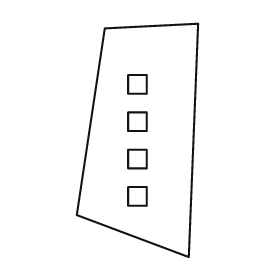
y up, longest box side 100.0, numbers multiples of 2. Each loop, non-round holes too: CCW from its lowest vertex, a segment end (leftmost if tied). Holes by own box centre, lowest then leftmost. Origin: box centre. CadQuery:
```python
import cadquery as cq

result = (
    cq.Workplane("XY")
    .moveTo(22.0, -50.0)
    .lineTo(26.0, 50.0)
    .lineTo(-14.0, 48.0)
    .lineTo(-26.0, -32.0)
    .close()
    .moveTo(-4.0, -28.0)
    .lineTo(4.0, -28.0)
    .lineTo(4.0, -20.0)
    .lineTo(-4.0, -20.0)
    .close()
    .moveTo(-4.0, -12.0)
    .lineTo(4.0, -12.0)
    .lineTo(4.0, -4.0)
    .lineTo(-4.0, -4.0)
    .close()
    .moveTo(-4.0, 4.0)
    .lineTo(4.0, 4.0)
    .lineTo(4.0, 12.0)
    .lineTo(-4.0, 12.0)
    .close()
    .moveTo(-4.0, 20.0)
    .lineTo(4.0, 20.0)
    .lineTo(4.0, 28.0)
    .lineTo(-4.0, 28.0)
    .close()
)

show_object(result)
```